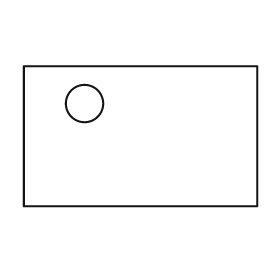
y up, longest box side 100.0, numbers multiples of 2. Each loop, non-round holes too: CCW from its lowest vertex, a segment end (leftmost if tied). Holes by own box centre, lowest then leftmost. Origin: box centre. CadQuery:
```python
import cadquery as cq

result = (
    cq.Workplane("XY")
    .moveTo(-50.0, -30.0)
    .lineTo(50.0, -30.0)
    .lineTo(50.0, 30.0)
    .lineTo(-50.0, 30.0)
    .close()
    .moveTo(-24.0, 14.0)
    .circle(8.0)
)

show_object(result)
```